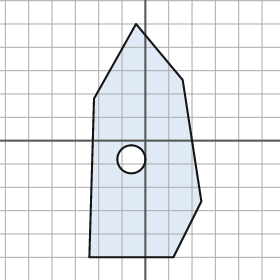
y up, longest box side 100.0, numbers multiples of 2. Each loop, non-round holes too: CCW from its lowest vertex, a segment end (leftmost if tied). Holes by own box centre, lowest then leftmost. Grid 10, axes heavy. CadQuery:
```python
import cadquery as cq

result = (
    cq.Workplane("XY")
    .moveTo(-24.0, -50.0)
    .lineTo(12.0, -50.0)
    .lineTo(24.0, -26.0)
    .lineTo(16.0, 26.0)
    .lineTo(-4.0, 50.0)
    .lineTo(-22.0, 18.0)
    .close()
    .moveTo(-6.0, -8.0)
    .circle(6.0)
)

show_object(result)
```